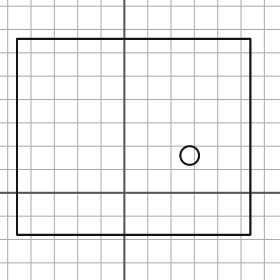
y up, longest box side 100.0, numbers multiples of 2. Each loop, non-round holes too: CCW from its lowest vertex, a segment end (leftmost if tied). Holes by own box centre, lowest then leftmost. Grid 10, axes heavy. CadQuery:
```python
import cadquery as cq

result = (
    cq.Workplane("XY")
    .moveTo(-46.0, -18.0)
    .lineTo(54.0, -18.0)
    .lineTo(54.0, 66.0)
    .lineTo(-46.0, 66.0)
    .close()
    .moveTo(28.0, 16.0)
    .circle(4.0)
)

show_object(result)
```